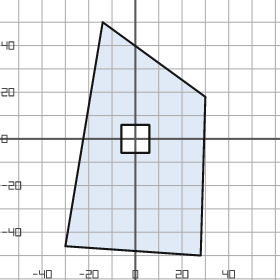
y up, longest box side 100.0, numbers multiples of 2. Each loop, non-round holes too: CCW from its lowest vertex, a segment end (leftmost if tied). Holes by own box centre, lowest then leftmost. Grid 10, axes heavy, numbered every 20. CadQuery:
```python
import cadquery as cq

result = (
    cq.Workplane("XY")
    .moveTo(28.0, -50.0)
    .lineTo(30.0, 18.0)
    .lineTo(-14.0, 50.0)
    .lineTo(-30.0, -46.0)
    .close()
    .moveTo(-6.0, -6.0)
    .lineTo(6.0, -6.0)
    .lineTo(6.0, 6.0)
    .lineTo(-6.0, 6.0)
    .close()
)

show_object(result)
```